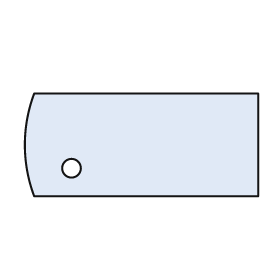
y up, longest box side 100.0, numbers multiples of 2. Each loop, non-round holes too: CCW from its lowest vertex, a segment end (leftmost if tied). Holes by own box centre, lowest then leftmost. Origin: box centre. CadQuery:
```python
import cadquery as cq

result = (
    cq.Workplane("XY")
    .moveTo(-46.0, -22.0)
    .lineTo(50.0, -22.0)
    .lineTo(50.0, 22.0)
    .lineTo(-46.0, 22.0)
    .threePointArc((-50.0, 0.0), (-46.0, -22.0))
    .close()
    .moveTo(-30.0, -10.0)
    .circle(4.0)
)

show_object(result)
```